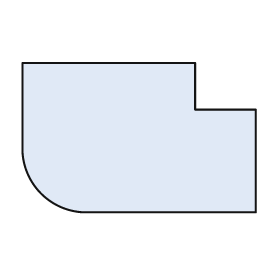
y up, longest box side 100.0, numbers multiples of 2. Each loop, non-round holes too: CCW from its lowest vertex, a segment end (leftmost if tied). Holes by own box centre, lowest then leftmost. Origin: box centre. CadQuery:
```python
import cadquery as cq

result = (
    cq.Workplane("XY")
    .moveTo(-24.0, -32.0)
    .lineTo(50.0, -32.0)
    .lineTo(50.0, 12.0)
    .lineTo(24.0, 12.0)
    .lineTo(24.0, 32.0)
    .lineTo(-50.0, 32.0)
    .lineTo(-50.0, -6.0)
    .threePointArc((-42.0, -24.0), (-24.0, -32.0))
    .close()
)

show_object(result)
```